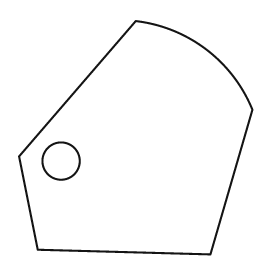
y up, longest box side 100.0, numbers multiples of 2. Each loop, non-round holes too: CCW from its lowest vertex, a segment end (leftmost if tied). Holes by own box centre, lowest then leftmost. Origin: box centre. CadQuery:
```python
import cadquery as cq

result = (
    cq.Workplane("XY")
    .moveTo(32.0, -50.0)
    .lineTo(50.0, 12.0)
    .threePointArc((30.0, 38.0), (0.0, 50.0))
    .lineTo(-50.0, -8.0)
    .lineTo(-42.0, -48.0)
    .close()
    .moveTo(-32.0, -10.0)
    .circle(8.0)
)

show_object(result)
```